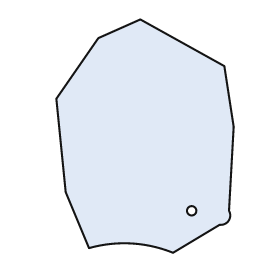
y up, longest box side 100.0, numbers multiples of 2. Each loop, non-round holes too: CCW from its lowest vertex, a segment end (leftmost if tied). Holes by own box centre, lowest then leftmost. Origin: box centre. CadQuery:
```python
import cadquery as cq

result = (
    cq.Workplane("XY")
    .moveTo(12.0, -50.0)
    .lineTo(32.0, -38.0)
    .threePointArc((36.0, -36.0), (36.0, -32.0))
    .lineTo(38.0, 4.0)
    .lineTo(34.0, 30.0)
    .lineTo(-2.0, 50.0)
    .lineTo(-20.0, 42.0)
    .lineTo(-38.0, 16.0)
    .lineTo(-34.0, -24.0)
    .lineTo(-24.0, -48.0)
    .threePointArc((-6.0, -46.0), (12.0, -50.0))
    .close()
    .moveTo(20.0, -32.0)
    .circle(2.0)
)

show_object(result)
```